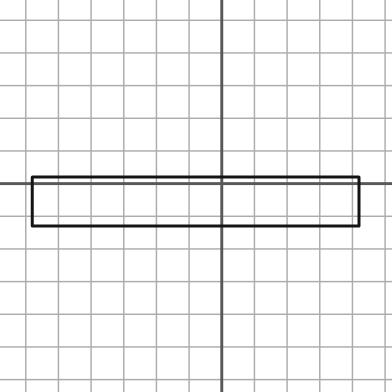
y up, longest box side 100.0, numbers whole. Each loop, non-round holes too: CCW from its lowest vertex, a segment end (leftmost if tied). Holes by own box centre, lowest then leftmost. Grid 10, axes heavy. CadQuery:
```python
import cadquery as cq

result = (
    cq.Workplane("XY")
    .moveTo(-58.0, -13.0)
    .lineTo(42.0, -13.0)
    .lineTo(42.0, 2.0)
    .lineTo(-58.0, 2.0)
    .close()
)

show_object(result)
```